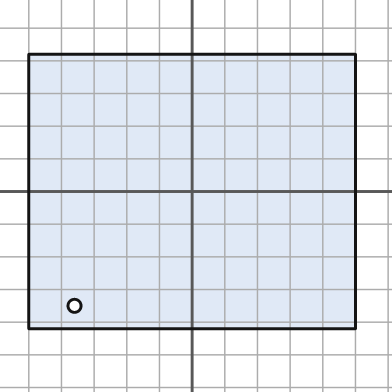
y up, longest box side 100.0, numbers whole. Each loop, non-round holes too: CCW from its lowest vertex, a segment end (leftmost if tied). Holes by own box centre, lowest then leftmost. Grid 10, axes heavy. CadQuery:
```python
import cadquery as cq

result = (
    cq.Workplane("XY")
    .moveTo(-50.0, -42.0)
    .lineTo(50.0, -42.0)
    .lineTo(50.0, 42.0)
    .lineTo(-50.0, 42.0)
    .close()
    .moveTo(-36.0, -35.0)
    .circle(2.0)
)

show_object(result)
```